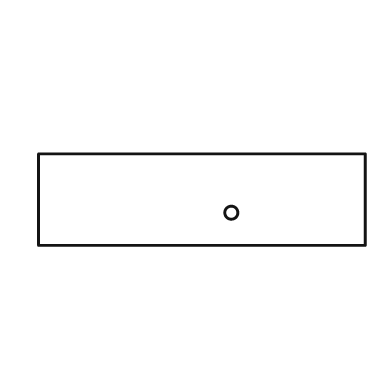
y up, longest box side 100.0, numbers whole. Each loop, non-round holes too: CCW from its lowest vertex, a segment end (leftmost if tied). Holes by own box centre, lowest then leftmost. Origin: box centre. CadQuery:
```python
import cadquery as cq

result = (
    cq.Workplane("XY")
    .moveTo(-50.0, -14.0)
    .lineTo(50.0, -14.0)
    .lineTo(50.0, 14.0)
    .lineTo(-50.0, 14.0)
    .close()
    .moveTo(9.0, -4.0)
    .circle(2.0)
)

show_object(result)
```